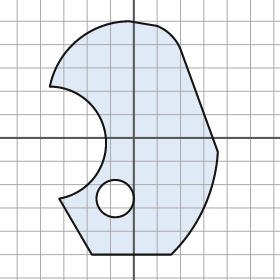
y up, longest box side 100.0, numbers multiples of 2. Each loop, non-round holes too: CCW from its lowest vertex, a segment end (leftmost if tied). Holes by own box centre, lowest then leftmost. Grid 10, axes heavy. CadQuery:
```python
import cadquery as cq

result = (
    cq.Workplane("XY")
    .moveTo(-18.0, -50.0)
    .lineTo(16.0, -50.0)
    .threePointArc((30.0, -30.0), (36.0, -6.0))
    .lineTo(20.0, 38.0)
    .threePointArc((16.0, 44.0), (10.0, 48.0))
    .lineTo(-2.0, 50.0)
    .threePointArc((-24.0, 42.0), (-36.0, 22.0))
    .threePointArc((-12.0, 0.0), (-32.0, -26.0))
    .close()
    .moveTo(-8.0, -26.0)
    .circle(8.0)
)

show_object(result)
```